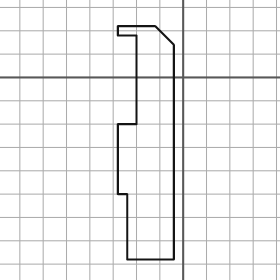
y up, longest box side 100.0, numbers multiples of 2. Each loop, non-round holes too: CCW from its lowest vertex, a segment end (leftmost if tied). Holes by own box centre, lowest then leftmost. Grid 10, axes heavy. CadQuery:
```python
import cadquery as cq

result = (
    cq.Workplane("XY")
    .moveTo(-24.0, -78.0)
    .lineTo(-4.0, -78.0)
    .lineTo(-4.0, 14.0)
    .lineTo(-12.0, 22.0)
    .lineTo(-28.0, 22.0)
    .lineTo(-28.0, 18.0)
    .lineTo(-20.0, 18.0)
    .lineTo(-20.0, -20.0)
    .lineTo(-28.0, -20.0)
    .lineTo(-28.0, -50.0)
    .lineTo(-24.0, -50.0)
    .close()
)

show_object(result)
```